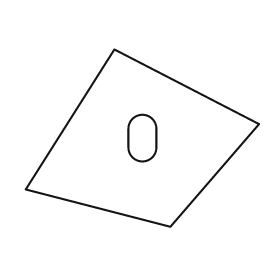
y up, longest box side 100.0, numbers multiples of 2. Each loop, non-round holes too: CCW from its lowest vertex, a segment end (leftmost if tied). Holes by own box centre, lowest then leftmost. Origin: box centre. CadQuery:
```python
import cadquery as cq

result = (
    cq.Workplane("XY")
    .moveTo(12.0, -38.0)
    .lineTo(50.0, 6.0)
    .lineTo(-12.0, 38.0)
    .lineTo(-50.0, -22.0)
    .close()
    .moveTo(-6.0, -4.0)
    .threePointArc((0.0, -10.0), (6.0, -4.0))
    .lineTo(6.0, 4.0)
    .threePointArc((0.0, 10.0), (-6.0, 4.0))
    .close()
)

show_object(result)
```